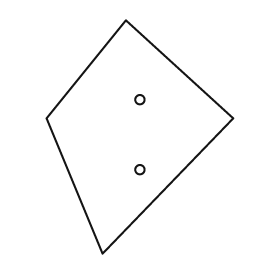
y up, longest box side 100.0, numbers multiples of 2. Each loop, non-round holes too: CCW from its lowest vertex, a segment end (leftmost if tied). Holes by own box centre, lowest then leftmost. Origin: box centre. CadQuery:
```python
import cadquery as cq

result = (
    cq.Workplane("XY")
    .moveTo(-16.0, -50.0)
    .lineTo(40.0, 8.0)
    .lineTo(-6.0, 50.0)
    .lineTo(-40.0, 8.0)
    .close()
    .moveTo(0.0, -14.0)
    .circle(2.0)
    .moveTo(0.0, 16.0)
    .circle(2.0)
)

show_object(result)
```